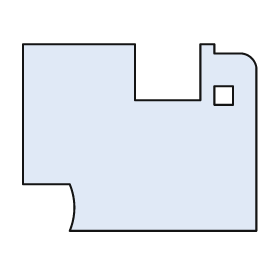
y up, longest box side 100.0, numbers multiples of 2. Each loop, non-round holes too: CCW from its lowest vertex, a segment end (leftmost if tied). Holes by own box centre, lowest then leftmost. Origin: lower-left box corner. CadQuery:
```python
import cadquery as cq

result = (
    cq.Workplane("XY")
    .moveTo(20.0, 0.0)
    .lineTo(100.0, 0.0)
    .lineTo(100.0, 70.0)
    .threePointArc((98.0, 74.0), (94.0, 76.0))
    .lineTo(82.0, 76.0)
    .lineTo(82.0, 80.0)
    .lineTo(76.0, 80.0)
    .lineTo(76.0, 56.0)
    .lineTo(48.0, 56.0)
    .lineTo(48.0, 80.0)
    .lineTo(0.0, 80.0)
    .lineTo(0.0, 20.0)
    .lineTo(20.0, 20.0)
    .threePointArc((22.0, 10.0), (20.0, 0.0))
    .close()
    .moveTo(82.0, 54.0)
    .lineTo(90.0, 54.0)
    .lineTo(90.0, 62.0)
    .lineTo(82.0, 62.0)
    .close()
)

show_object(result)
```